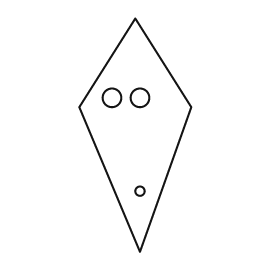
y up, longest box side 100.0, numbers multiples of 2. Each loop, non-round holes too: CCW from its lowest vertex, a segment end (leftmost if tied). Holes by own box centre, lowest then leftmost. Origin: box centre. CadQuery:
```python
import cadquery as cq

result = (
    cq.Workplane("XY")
    .moveTo(2.0, -50.0)
    .lineTo(24.0, 12.0)
    .lineTo(0.0, 50.0)
    .lineTo(-24.0, 12.0)
    .close()
    .moveTo(2.0, -24.0)
    .circle(2.0)
    .moveTo(-10.0, 16.0)
    .circle(4.0)
    .moveTo(2.0, 16.0)
    .circle(4.0)
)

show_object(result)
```